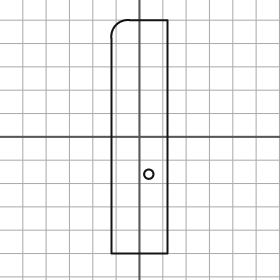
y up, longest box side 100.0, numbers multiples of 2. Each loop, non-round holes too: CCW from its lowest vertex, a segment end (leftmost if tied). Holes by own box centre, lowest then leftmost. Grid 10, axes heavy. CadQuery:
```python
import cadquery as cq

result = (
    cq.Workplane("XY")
    .moveTo(-12.0, -50.0)
    .lineTo(12.0, -50.0)
    .lineTo(12.0, 50.0)
    .lineTo(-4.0, 50.0)
    .threePointArc((-10.0, 48.0), (-12.0, 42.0))
    .close()
    .moveTo(4.0, -16.0)
    .circle(2.0)
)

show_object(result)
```